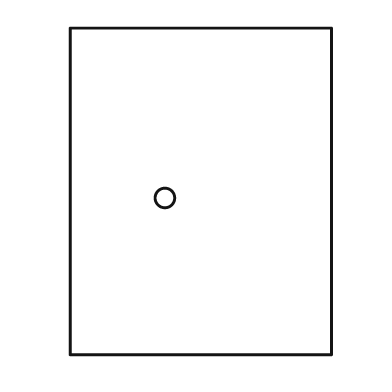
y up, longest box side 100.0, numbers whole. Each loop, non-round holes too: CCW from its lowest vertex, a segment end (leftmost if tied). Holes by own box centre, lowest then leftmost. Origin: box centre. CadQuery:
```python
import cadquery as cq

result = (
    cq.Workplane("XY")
    .moveTo(-40.0, -50.0)
    .lineTo(40.0, -50.0)
    .lineTo(40.0, 50.0)
    .lineTo(-40.0, 50.0)
    .close()
    .moveTo(-11.0, -2.0)
    .circle(3.0)
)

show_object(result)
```